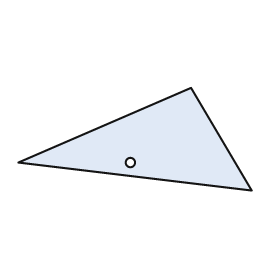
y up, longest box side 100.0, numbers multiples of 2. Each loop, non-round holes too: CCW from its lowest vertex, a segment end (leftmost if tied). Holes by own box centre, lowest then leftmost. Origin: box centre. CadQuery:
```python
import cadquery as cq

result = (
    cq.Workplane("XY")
    .moveTo(50.0, -22.0)
    .lineTo(24.0, 22.0)
    .lineTo(-50.0, -10.0)
    .close()
    .moveTo(-2.0, -10.0)
    .circle(2.0)
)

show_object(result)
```